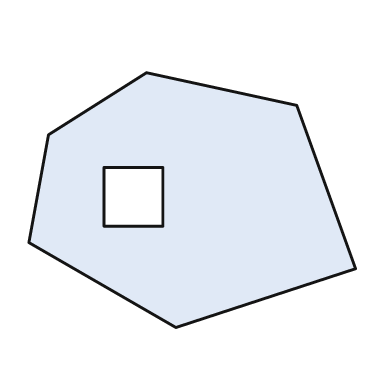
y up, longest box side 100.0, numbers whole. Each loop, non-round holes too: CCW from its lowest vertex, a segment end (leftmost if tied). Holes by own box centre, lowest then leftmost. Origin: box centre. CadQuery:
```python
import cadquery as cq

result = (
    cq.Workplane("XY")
    .moveTo(-5.0, -39.0)
    .lineTo(50.0, -21.0)
    .lineTo(32.0, 29.0)
    .lineTo(-14.0, 39.0)
    .lineTo(-44.0, 20.0)
    .lineTo(-50.0, -13.0)
    .close()
    .moveTo(-27.0, -8.0)
    .lineTo(-9.0, -8.0)
    .lineTo(-9.0, 10.0)
    .lineTo(-27.0, 10.0)
    .close()
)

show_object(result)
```